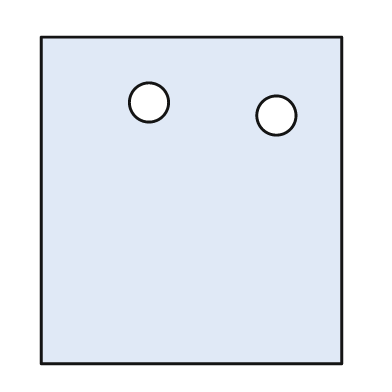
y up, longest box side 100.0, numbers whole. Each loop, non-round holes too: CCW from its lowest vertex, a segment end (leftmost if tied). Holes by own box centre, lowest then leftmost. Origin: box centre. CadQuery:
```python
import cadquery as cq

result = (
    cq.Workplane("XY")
    .moveTo(-46.0, -50.0)
    .lineTo(46.0, -50.0)
    .lineTo(46.0, 50.0)
    .lineTo(-46.0, 50.0)
    .close()
    .moveTo(26.0, 26.0)
    .circle(6.0)
    .moveTo(-13.0, 30.0)
    .circle(6.0)
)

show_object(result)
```